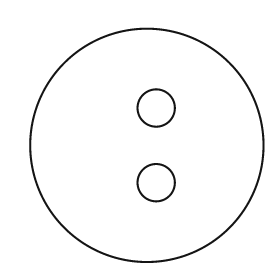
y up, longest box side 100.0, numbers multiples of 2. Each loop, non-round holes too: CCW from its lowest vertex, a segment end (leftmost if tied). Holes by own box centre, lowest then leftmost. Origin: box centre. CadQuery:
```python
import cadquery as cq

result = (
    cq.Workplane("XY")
    .moveTo(0.0, 0.0)
    .circle(50.0)
    .moveTo(4.0, -16.0)
    .circle(8.0)
    .moveTo(4.0, 16.0)
    .circle(8.0)
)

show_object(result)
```